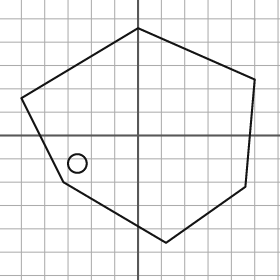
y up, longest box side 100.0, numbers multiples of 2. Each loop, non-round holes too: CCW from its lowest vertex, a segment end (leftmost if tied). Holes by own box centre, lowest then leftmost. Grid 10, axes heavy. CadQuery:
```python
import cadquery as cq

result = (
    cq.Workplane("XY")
    .moveTo(12.0, -46.0)
    .lineTo(46.0, -22.0)
    .lineTo(50.0, 24.0)
    .lineTo(0.0, 46.0)
    .lineTo(-50.0, 16.0)
    .lineTo(-32.0, -20.0)
    .close()
    .moveTo(-26.0, -12.0)
    .circle(4.0)
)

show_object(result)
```